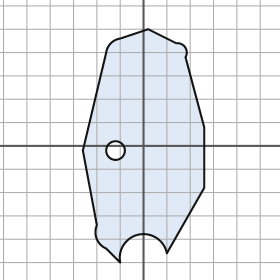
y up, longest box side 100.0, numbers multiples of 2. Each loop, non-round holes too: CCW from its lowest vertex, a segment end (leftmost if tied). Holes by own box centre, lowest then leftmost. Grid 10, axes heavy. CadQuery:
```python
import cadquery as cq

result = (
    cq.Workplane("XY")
    .moveTo(-10.0, -50.0)
    .threePointArc((-2.0, -38.0), (10.0, -46.0))
    .lineTo(26.0, -18.0)
    .lineTo(26.0, 8.0)
    .lineTo(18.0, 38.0)
    .threePointArc((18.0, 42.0), (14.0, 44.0))
    .lineTo(2.0, 50.0)
    .lineTo(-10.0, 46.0)
    .threePointArc((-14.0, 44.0), (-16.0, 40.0))
    .lineTo(-26.0, -2.0)
    .lineTo(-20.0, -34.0)
    .threePointArc((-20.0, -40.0), (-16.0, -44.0))
    .close()
    .moveTo(-12.0, -2.0)
    .circle(4.0)
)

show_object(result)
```